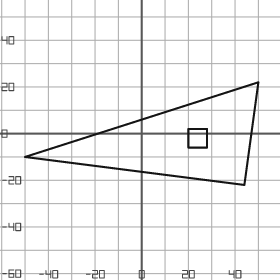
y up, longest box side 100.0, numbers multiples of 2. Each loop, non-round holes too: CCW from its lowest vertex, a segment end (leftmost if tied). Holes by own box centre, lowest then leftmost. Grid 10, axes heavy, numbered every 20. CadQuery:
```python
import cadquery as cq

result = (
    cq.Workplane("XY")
    .moveTo(44.0, -22.0)
    .lineTo(50.0, 22.0)
    .lineTo(-50.0, -10.0)
    .close()
    .moveTo(20.0, -6.0)
    .lineTo(28.0, -6.0)
    .lineTo(28.0, 2.0)
    .lineTo(20.0, 2.0)
    .close()
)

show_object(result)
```